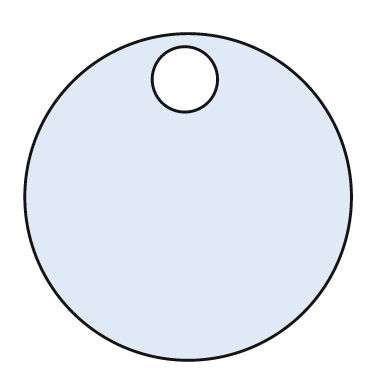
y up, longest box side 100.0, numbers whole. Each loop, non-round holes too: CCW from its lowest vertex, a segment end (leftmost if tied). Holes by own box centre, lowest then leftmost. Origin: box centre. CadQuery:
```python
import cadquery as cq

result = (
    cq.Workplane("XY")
    .moveTo(0.0, 0.0)
    .circle(50.0)
    .moveTo(-1.0, 36.0)
    .circle(10.0)
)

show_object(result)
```